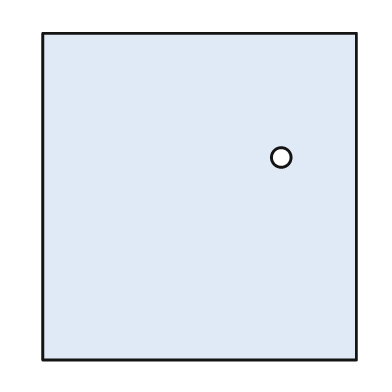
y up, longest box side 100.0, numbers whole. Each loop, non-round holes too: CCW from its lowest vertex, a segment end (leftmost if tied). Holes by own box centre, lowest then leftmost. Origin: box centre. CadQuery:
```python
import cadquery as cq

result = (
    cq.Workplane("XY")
    .moveTo(-48.0, -50.0)
    .lineTo(48.0, -50.0)
    .lineTo(48.0, 50.0)
    .lineTo(-48.0, 50.0)
    .close()
    .moveTo(25.0, 12.0)
    .circle(3.0)
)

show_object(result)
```